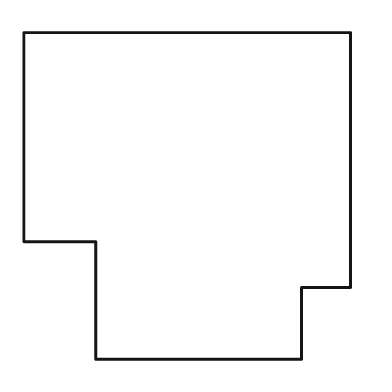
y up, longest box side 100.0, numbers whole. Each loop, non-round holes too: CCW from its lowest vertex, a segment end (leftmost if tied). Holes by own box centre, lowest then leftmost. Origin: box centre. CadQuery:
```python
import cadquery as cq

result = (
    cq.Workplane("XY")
    .moveTo(-28.0, -50.0)
    .lineTo(35.0, -50.0)
    .lineTo(35.0, -28.0)
    .lineTo(50.0, -28.0)
    .lineTo(50.0, 50.0)
    .lineTo(-50.0, 50.0)
    .lineTo(-50.0, -14.0)
    .lineTo(-28.0, -14.0)
    .close()
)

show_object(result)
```